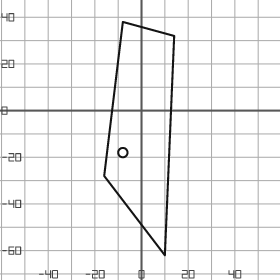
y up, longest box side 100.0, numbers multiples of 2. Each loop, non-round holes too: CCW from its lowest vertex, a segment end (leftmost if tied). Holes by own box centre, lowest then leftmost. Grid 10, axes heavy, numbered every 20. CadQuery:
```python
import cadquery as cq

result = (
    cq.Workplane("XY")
    .moveTo(10.0, -62.0)
    .lineTo(14.0, 32.0)
    .lineTo(-8.0, 38.0)
    .lineTo(-16.0, -28.0)
    .close()
    .moveTo(-8.0, -18.0)
    .circle(2.0)
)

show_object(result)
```